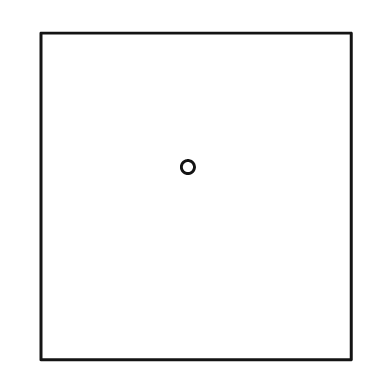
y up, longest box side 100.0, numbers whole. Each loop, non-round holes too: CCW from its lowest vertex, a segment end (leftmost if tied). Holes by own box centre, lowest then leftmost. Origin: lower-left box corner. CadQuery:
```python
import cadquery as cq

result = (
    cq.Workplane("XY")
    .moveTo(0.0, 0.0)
    .lineTo(95.0, 0.0)
    .lineTo(95.0, 100.0)
    .lineTo(0.0, 100.0)
    .close()
    .moveTo(45.0, 59.0)
    .circle(2.0)
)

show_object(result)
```